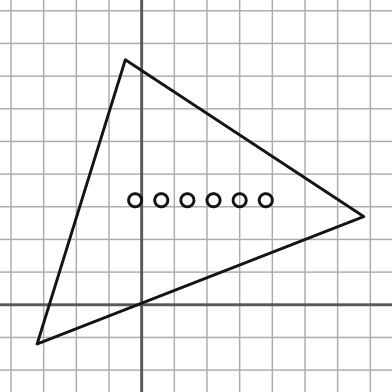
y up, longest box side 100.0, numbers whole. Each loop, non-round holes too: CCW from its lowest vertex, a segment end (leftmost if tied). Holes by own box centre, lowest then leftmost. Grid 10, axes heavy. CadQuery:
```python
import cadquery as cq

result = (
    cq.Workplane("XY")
    .moveTo(-32.0, -12.0)
    .lineTo(68.0, 27.0)
    .lineTo(-5.0, 75.0)
    .close()
    .moveTo(-2.0, 32.0)
    .circle(2.0)
    .moveTo(6.0, 32.0)
    .circle(2.0)
    .moveTo(14.0, 32.0)
    .circle(2.0)
    .moveTo(22.0, 32.0)
    .circle(2.0)
    .moveTo(30.0, 32.0)
    .circle(2.0)
    .moveTo(38.0, 32.0)
    .circle(2.0)
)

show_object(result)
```